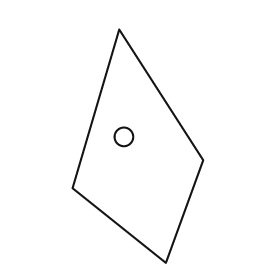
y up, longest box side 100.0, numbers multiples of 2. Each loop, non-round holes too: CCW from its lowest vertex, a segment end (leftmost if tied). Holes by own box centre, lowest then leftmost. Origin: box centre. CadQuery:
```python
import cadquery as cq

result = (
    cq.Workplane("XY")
    .moveTo(12.0, -50.0)
    .lineTo(28.0, -6.0)
    .lineTo(-8.0, 50.0)
    .lineTo(-28.0, -18.0)
    .close()
    .moveTo(-6.0, 4.0)
    .circle(4.0)
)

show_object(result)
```